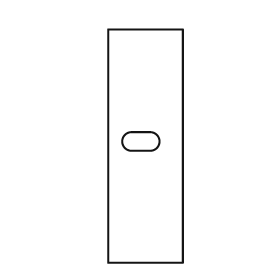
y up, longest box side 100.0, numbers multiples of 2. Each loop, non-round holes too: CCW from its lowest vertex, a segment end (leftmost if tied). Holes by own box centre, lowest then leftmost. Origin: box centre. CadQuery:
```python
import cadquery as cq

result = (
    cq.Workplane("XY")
    .moveTo(-16.0, -50.0)
    .lineTo(16.0, -50.0)
    .lineTo(16.0, 50.0)
    .lineTo(-16.0, 50.0)
    .close()
    .moveTo(-6.0, -2.0)
    .lineTo(2.0, -2.0)
    .threePointArc((6.0, 2.0), (2.0, 6.0))
    .lineTo(-6.0, 6.0)
    .threePointArc((-10.0, 2.0), (-6.0, -2.0))
    .close()
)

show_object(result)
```